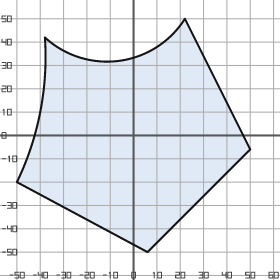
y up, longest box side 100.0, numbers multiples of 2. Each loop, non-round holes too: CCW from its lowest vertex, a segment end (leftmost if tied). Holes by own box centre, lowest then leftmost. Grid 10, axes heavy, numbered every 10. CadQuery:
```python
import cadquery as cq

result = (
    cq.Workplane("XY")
    .moveTo(6.0, -50.0)
    .lineTo(50.0, -6.0)
    .lineTo(22.0, 50.0)
    .threePointArc((-6.0, 32.0), (-38.0, 42.0))
    .threePointArc((-40.0, 10.0), (-50.0, -20.0))
    .close()
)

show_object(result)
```